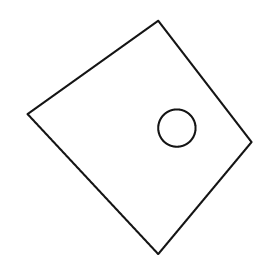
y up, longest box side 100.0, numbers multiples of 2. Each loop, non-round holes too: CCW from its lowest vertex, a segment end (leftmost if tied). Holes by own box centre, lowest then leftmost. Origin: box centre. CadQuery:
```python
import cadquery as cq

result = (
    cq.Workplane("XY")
    .moveTo(8.0, -50.0)
    .lineTo(48.0, -2.0)
    .lineTo(8.0, 50.0)
    .lineTo(-48.0, 10.0)
    .close()
    .moveTo(16.0, 4.0)
    .circle(8.0)
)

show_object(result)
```